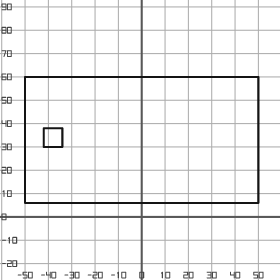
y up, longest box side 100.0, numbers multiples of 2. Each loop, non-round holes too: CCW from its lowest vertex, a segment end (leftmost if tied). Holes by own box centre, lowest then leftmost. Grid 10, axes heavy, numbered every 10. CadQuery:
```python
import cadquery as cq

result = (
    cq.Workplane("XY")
    .moveTo(-50.0, 6.0)
    .lineTo(50.0, 6.0)
    .lineTo(50.0, 60.0)
    .lineTo(-50.0, 60.0)
    .close()
    .moveTo(-42.0, 30.0)
    .lineTo(-34.0, 30.0)
    .lineTo(-34.0, 38.0)
    .lineTo(-42.0, 38.0)
    .close()
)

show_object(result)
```